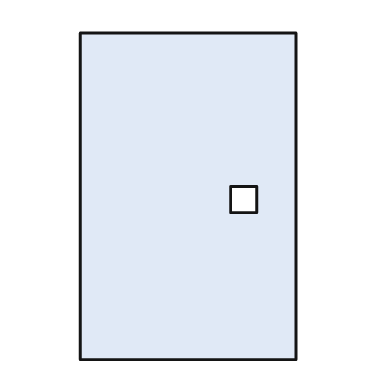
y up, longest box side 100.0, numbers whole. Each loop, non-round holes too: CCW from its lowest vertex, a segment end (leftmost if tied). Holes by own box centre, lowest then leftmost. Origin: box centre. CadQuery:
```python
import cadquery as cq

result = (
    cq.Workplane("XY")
    .moveTo(-33.0, -50.0)
    .lineTo(33.0, -50.0)
    .lineTo(33.0, 50.0)
    .lineTo(-33.0, 50.0)
    .close()
    .moveTo(13.0, -5.0)
    .lineTo(21.0, -5.0)
    .lineTo(21.0, 3.0)
    .lineTo(13.0, 3.0)
    .close()
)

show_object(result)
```